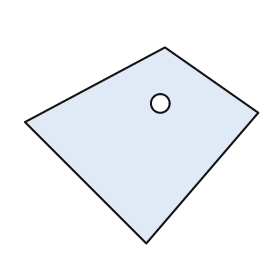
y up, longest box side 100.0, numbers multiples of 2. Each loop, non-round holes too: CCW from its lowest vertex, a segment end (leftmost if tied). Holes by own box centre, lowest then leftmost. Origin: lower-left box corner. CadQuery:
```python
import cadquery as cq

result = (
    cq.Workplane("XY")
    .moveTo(52.0, 0.0)
    .lineTo(100.0, 56.0)
    .lineTo(60.0, 84.0)
    .lineTo(0.0, 52.0)
    .close()
    .moveTo(58.0, 60.0)
    .circle(4.0)
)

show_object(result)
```